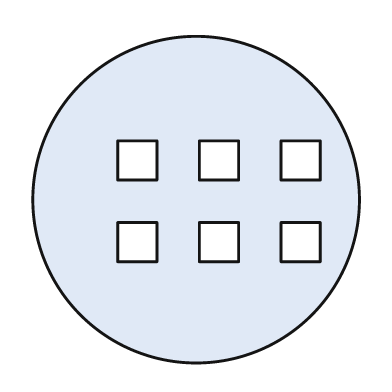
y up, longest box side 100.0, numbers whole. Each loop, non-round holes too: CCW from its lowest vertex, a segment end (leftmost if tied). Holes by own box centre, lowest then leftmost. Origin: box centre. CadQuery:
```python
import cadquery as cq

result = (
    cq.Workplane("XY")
    .moveTo(0.0, 0.0)
    .circle(50.0)
    .moveTo(-24.0, -19.0)
    .lineTo(-12.0, -19.0)
    .lineTo(-12.0, -7.0)
    .lineTo(-24.0, -7.0)
    .close()
    .moveTo(1.0, -19.0)
    .lineTo(13.0, -19.0)
    .lineTo(13.0, -7.0)
    .lineTo(1.0, -7.0)
    .close()
    .moveTo(26.0, -19.0)
    .lineTo(38.0, -19.0)
    .lineTo(38.0, -7.0)
    .lineTo(26.0, -7.0)
    .close()
    .moveTo(-24.0, 6.0)
    .lineTo(-12.0, 6.0)
    .lineTo(-12.0, 18.0)
    .lineTo(-24.0, 18.0)
    .close()
    .moveTo(1.0, 6.0)
    .lineTo(13.0, 6.0)
    .lineTo(13.0, 18.0)
    .lineTo(1.0, 18.0)
    .close()
    .moveTo(26.0, 6.0)
    .lineTo(38.0, 6.0)
    .lineTo(38.0, 18.0)
    .lineTo(26.0, 18.0)
    .close()
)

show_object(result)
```